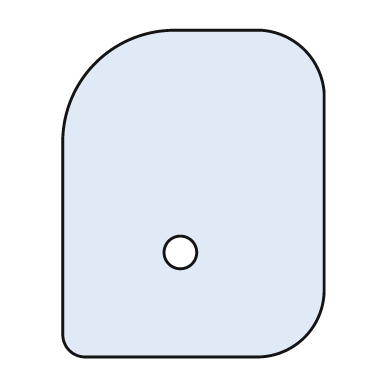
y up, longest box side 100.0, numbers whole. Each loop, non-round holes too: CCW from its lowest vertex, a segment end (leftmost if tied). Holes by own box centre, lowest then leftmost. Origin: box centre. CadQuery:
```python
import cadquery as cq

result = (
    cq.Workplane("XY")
    .moveTo(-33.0, -50.0)
    .lineTo(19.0, -50.0)
    .threePointArc((34.0, -44.0), (40.0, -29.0))
    .lineTo(40.0, 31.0)
    .threePointArc((34.0, 44.0), (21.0, 50.0))
    .lineTo(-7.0, 50.0)
    .threePointArc((-30.0, 40.0), (-40.0, 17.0))
    .lineTo(-40.0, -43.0)
    .threePointArc((-38.0, -48.0), (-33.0, -50.0))
    .close()
    .moveTo(-4.0, -18.0)
    .circle(5.0)
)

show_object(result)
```